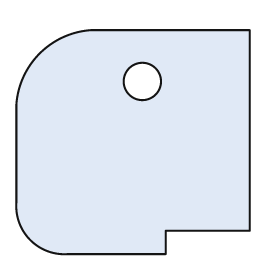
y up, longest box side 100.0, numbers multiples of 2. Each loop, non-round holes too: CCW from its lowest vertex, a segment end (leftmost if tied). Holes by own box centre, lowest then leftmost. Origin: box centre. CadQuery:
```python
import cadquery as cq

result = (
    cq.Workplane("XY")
    .moveTo(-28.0, -48.0)
    .lineTo(14.0, -48.0)
    .lineTo(14.0, -38.0)
    .lineTo(50.0, -38.0)
    .lineTo(50.0, 48.0)
    .lineTo(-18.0, 48.0)
    .threePointArc((-40.0, 38.0), (-50.0, 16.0))
    .lineTo(-50.0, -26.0)
    .threePointArc((-44.0, -42.0), (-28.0, -48.0))
    .close()
    .moveTo(4.0, 26.0)
    .circle(8.0)
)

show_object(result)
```